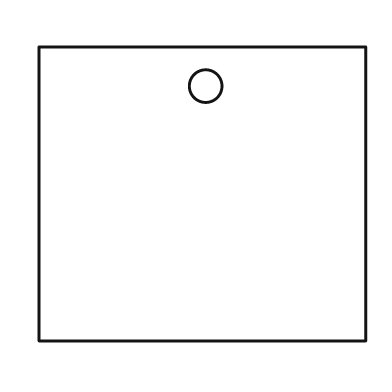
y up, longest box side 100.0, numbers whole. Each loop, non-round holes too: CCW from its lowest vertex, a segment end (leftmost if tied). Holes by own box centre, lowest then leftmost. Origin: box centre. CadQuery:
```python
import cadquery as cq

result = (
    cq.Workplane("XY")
    .moveTo(-50.0, -45.0)
    .lineTo(50.0, -45.0)
    .lineTo(50.0, 45.0)
    .lineTo(-50.0, 45.0)
    .close()
    .moveTo(1.0, 33.0)
    .circle(5.0)
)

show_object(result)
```